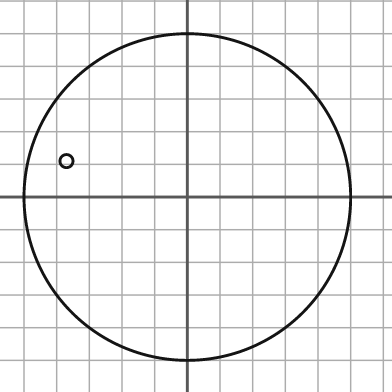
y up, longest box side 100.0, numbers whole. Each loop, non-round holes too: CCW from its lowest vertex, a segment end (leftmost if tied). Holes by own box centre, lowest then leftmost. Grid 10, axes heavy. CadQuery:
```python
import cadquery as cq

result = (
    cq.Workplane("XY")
    .moveTo(0.0, 0.0)
    .circle(50.0)
    .moveTo(-37.0, 11.0)
    .circle(2.0)
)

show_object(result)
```